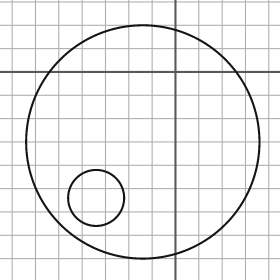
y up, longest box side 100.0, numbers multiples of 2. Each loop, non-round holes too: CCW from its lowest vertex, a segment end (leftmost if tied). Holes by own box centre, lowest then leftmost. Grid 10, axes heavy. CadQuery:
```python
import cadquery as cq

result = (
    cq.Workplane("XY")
    .moveTo(-14.0, -30.0)
    .circle(50.0)
    .moveTo(-34.0, -54.0)
    .circle(12.0)
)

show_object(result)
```